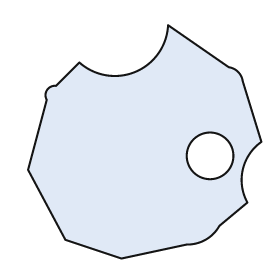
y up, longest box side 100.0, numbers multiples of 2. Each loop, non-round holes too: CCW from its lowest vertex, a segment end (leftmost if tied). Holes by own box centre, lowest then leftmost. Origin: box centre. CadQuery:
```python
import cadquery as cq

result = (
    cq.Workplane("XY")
    .moveTo(-10.0, -50.0)
    .lineTo(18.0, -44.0)
    .threePointArc((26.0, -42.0), (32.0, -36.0))
    .lineTo(44.0, -26.0)
    .threePointArc((42.0, -12.0), (50.0, 0.0))
    .lineTo(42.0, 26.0)
    .threePointArc((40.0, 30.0), (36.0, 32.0))
    .lineTo(10.0, 50.0)
    .threePointArc((-4.0, 30.0), (-28.0, 34.0))
    .lineTo(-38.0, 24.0)
    .threePointArc((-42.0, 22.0), (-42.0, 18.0))
    .lineTo(-50.0, -12.0)
    .lineTo(-34.0, -42.0)
    .close()
    .moveTo(28.0, -6.0)
    .circle(10.0)
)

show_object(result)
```